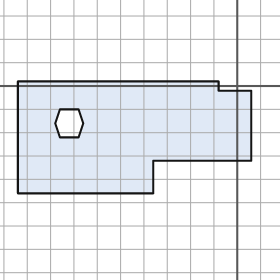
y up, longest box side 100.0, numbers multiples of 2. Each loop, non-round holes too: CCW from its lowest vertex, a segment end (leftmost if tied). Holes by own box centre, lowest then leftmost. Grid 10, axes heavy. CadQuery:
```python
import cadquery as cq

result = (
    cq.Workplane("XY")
    .moveTo(-94.0, -46.0)
    .lineTo(-36.0, -46.0)
    .lineTo(-36.0, -32.0)
    .lineTo(6.0, -32.0)
    .lineTo(6.0, -2.0)
    .lineTo(-8.0, -2.0)
    .lineTo(-8.0, 2.0)
    .lineTo(-94.0, 2.0)
    .close()
    .moveTo(-76.0, -22.0)
    .lineTo(-68.0, -22.0)
    .lineTo(-66.0, -16.0)
    .lineTo(-68.0, -10.0)
    .lineTo(-76.0, -10.0)
    .lineTo(-78.0, -16.0)
    .close()
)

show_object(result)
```